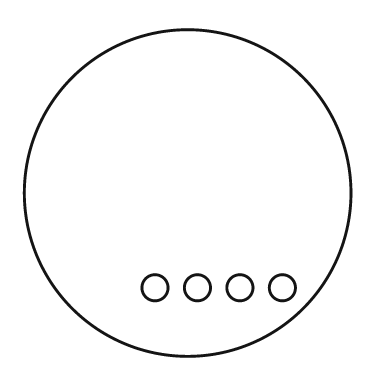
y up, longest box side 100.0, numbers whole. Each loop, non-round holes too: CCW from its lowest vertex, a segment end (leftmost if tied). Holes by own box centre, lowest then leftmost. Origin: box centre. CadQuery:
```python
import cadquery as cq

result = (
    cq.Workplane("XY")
    .moveTo(0.0, 0.0)
    .circle(50.0)
    .moveTo(-10.0, -29.0)
    .circle(4.0)
    .moveTo(3.0, -29.0)
    .circle(4.0)
    .moveTo(16.0, -29.0)
    .circle(4.0)
    .moveTo(29.0, -29.0)
    .circle(4.0)
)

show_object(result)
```